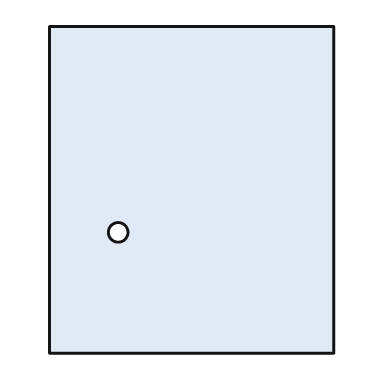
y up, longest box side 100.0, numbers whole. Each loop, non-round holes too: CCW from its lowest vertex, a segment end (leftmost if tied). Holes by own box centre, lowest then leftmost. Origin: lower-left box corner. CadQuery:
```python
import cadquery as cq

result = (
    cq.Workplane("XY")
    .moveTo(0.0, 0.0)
    .lineTo(87.0, 0.0)
    .lineTo(87.0, 100.0)
    .lineTo(0.0, 100.0)
    .close()
    .moveTo(21.0, 37.0)
    .circle(3.0)
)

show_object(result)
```